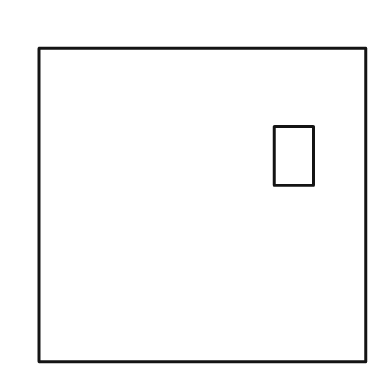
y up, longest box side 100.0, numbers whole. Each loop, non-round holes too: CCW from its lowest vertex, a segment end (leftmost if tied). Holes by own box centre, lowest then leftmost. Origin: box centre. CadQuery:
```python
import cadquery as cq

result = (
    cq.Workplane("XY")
    .moveTo(-50.0, -48.0)
    .lineTo(50.0, -48.0)
    .lineTo(50.0, 48.0)
    .lineTo(-50.0, 48.0)
    .close()
    .moveTo(22.0, 6.0)
    .lineTo(34.0, 6.0)
    .lineTo(34.0, 24.0)
    .lineTo(22.0, 24.0)
    .close()
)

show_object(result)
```